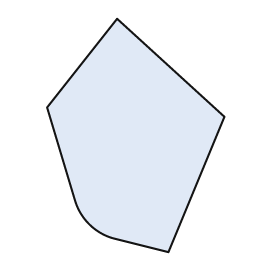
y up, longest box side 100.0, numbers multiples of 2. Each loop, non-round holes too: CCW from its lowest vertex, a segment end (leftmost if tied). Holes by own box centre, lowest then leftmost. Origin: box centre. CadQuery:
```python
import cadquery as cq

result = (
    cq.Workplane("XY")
    .moveTo(14.0, -50.0)
    .lineTo(38.0, 8.0)
    .lineTo(-8.0, 50.0)
    .lineTo(-38.0, 12.0)
    .lineTo(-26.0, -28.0)
    .threePointArc((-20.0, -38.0), (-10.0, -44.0))
    .close()
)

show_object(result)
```